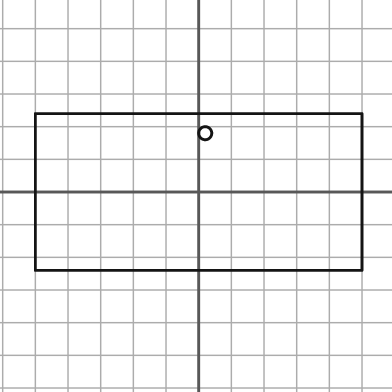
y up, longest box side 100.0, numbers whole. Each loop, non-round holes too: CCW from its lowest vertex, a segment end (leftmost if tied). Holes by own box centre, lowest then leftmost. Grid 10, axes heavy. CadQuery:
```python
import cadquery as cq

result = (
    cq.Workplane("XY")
    .moveTo(-50.0, -24.0)
    .lineTo(50.0, -24.0)
    .lineTo(50.0, 24.0)
    .lineTo(-50.0, 24.0)
    .close()
    .moveTo(2.0, 18.0)
    .circle(2.0)
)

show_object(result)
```